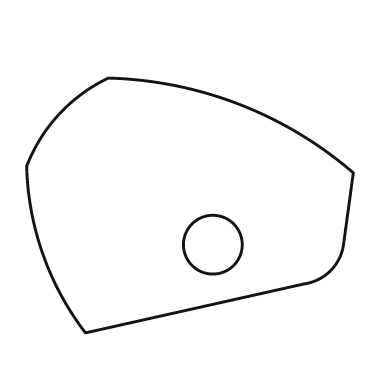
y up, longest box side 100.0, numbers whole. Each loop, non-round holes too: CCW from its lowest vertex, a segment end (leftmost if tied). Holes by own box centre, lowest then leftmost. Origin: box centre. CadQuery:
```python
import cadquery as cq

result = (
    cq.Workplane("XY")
    .moveTo(-32.0, -39.0)
    .lineTo(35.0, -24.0)
    .threePointArc((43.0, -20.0), (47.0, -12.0))
    .lineTo(50.0, 10.0)
    .threePointArc((15.0, 31.0), (-25.0, 39.0))
    .threePointArc((-40.0, 28.0), (-50.0, 12.0))
    .threePointArc((-45.0, -15.0), (-32.0, -39.0))
    .close()
    .moveTo(7.0, -12.0)
    .circle(9.0)
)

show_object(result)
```